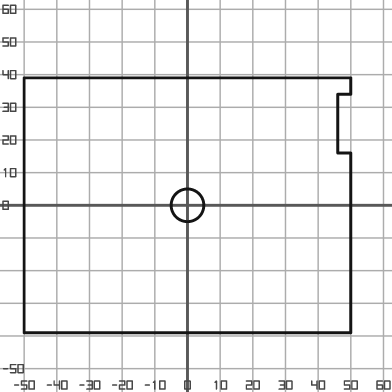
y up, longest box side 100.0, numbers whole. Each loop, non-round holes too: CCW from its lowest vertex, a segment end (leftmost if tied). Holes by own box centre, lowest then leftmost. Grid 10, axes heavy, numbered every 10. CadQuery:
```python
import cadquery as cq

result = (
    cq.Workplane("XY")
    .moveTo(-50.0, -39.0)
    .lineTo(50.0, -39.0)
    .lineTo(50.0, 16.0)
    .lineTo(46.0, 16.0)
    .lineTo(46.0, 34.0)
    .lineTo(50.0, 34.0)
    .lineTo(50.0, 39.0)
    .lineTo(-50.0, 39.0)
    .close()
    .moveTo(0.0, 0.0)
    .circle(5.0)
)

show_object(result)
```